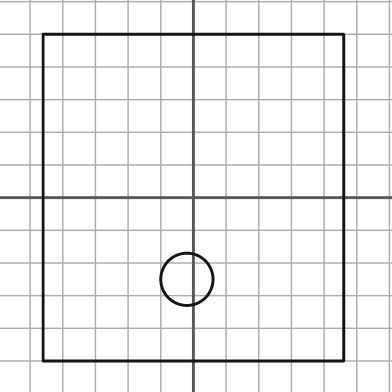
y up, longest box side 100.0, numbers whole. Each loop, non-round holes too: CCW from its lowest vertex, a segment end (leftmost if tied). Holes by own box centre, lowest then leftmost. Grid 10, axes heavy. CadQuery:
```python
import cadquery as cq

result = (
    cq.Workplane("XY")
    .moveTo(-46.0, -50.0)
    .lineTo(46.0, -50.0)
    .lineTo(46.0, 50.0)
    .lineTo(-46.0, 50.0)
    .close()
    .moveTo(-2.0, -25.0)
    .circle(8.0)
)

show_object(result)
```